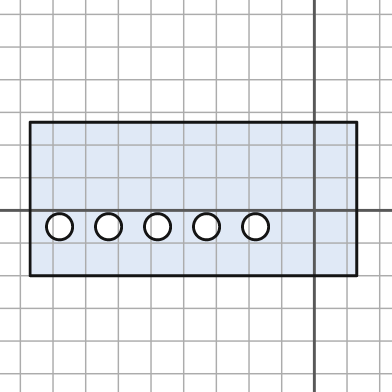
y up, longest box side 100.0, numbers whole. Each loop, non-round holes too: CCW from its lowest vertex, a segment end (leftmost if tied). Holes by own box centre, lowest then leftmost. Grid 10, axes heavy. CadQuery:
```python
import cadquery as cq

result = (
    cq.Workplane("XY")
    .moveTo(-87.0, -20.0)
    .lineTo(13.0, -20.0)
    .lineTo(13.0, 27.0)
    .lineTo(-87.0, 27.0)
    .close()
    .moveTo(-78.0, -5.0)
    .circle(4.0)
    .moveTo(-63.0, -5.0)
    .circle(4.0)
    .moveTo(-48.0, -5.0)
    .circle(4.0)
    .moveTo(-33.0, -5.0)
    .circle(4.0)
    .moveTo(-18.0, -5.0)
    .circle(4.0)
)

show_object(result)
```